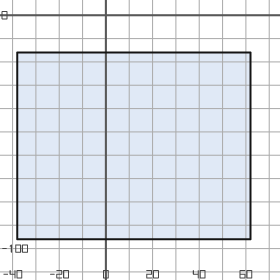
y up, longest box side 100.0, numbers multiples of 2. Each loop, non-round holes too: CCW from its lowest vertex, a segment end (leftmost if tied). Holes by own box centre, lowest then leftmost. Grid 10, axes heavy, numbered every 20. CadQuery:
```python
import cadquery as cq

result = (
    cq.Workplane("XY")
    .moveTo(-38.0, -96.0)
    .lineTo(62.0, -96.0)
    .lineTo(62.0, -16.0)
    .lineTo(-38.0, -16.0)
    .close()
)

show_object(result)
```